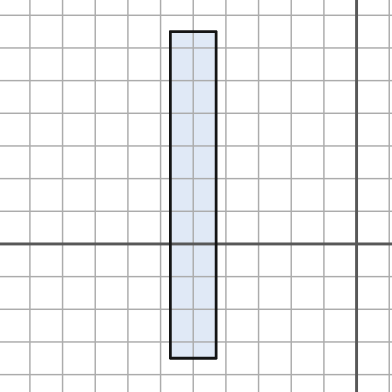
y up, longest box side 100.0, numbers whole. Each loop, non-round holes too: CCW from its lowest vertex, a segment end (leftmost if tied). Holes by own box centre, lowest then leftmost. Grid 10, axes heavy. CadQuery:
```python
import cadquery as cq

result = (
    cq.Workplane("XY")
    .moveTo(-57.0, -35.0)
    .lineTo(-43.0, -35.0)
    .lineTo(-43.0, 65.0)
    .lineTo(-57.0, 65.0)
    .close()
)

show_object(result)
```